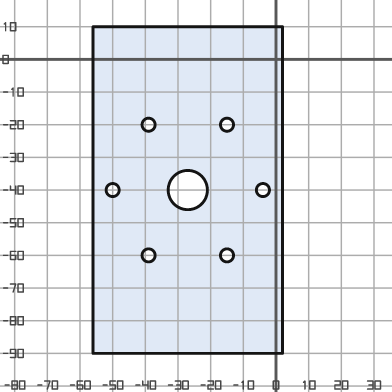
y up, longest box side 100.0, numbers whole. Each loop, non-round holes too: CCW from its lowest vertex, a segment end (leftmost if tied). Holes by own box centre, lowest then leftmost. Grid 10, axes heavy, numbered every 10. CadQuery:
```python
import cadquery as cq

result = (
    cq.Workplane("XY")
    .moveTo(-56.0, -90.0)
    .lineTo(2.0, -90.0)
    .lineTo(2.0, 10.0)
    .lineTo(-56.0, 10.0)
    .close()
    .moveTo(-39.0, -60.0)
    .circle(2.0)
    .moveTo(-15.0, -60.0)
    .circle(2.0)
    .moveTo(-50.0, -40.0)
    .circle(2.0)
    .moveTo(-27.0, -40.0)
    .circle(6.0)
    .moveTo(-4.0, -40.0)
    .circle(2.0)
    .moveTo(-39.0, -20.0)
    .circle(2.0)
    .moveTo(-15.0, -20.0)
    .circle(2.0)
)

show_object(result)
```